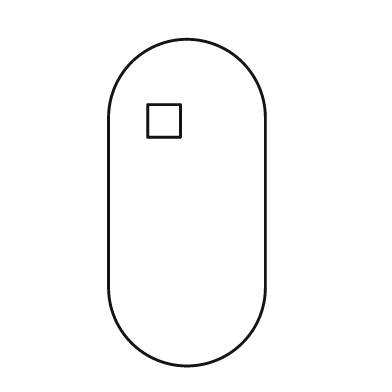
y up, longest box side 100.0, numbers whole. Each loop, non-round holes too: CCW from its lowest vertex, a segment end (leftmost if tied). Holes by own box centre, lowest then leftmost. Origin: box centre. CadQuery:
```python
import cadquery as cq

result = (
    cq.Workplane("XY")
    .moveTo(-24.0, -26.0)
    .threePointArc((0.0, -50.0), (24.0, -26.0))
    .lineTo(24.0, 26.0)
    .threePointArc((0.0, 50.0), (-24.0, 26.0))
    .close()
    .moveTo(-12.0, 20.0)
    .lineTo(-2.0, 20.0)
    .lineTo(-2.0, 30.0)
    .lineTo(-12.0, 30.0)
    .close()
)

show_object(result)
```